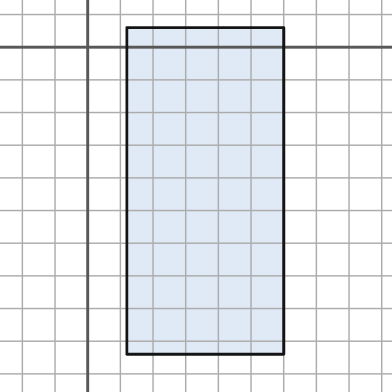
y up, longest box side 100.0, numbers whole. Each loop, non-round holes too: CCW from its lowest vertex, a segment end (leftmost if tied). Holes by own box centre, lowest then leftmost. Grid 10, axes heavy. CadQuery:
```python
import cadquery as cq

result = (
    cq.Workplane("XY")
    .moveTo(12.0, -94.0)
    .lineTo(60.0, -94.0)
    .lineTo(60.0, 6.0)
    .lineTo(12.0, 6.0)
    .close()
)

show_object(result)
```